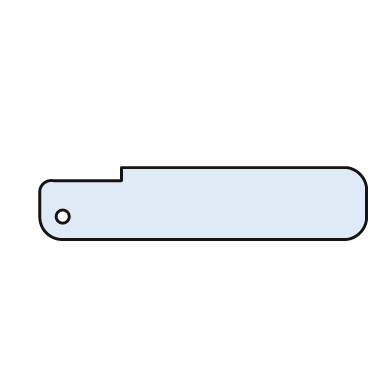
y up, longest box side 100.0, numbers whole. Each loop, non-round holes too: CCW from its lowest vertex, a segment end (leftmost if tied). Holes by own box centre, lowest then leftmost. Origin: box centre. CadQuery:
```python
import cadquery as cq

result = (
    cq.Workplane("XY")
    .moveTo(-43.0, -11.0)
    .lineTo(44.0, -11.0)
    .threePointArc((48.0, -9.0), (50.0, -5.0))
    .lineTo(50.0, 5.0)
    .threePointArc((48.0, 9.0), (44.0, 11.0))
    .lineTo(-25.0, 11.0)
    .lineTo(-25.0, 7.0)
    .lineTo(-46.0, 7.0)
    .threePointArc((-49.0, 6.0), (-50.0, 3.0))
    .lineTo(-50.0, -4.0)
    .threePointArc((-48.0, -9.0), (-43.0, -11.0))
    .close()
    .moveTo(-43.0, -4.0)
    .circle(2.0)
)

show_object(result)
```